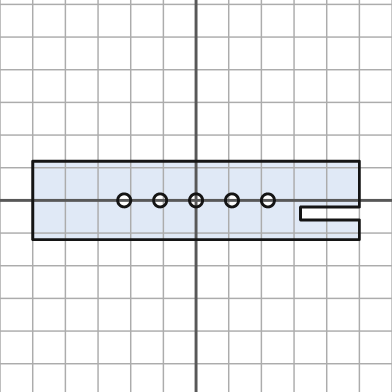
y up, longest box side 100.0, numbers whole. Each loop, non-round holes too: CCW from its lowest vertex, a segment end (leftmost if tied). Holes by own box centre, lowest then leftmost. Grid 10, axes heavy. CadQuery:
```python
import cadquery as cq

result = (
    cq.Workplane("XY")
    .moveTo(-50.0, -12.0)
    .lineTo(50.0, -12.0)
    .lineTo(50.0, -6.0)
    .lineTo(32.0, -6.0)
    .lineTo(32.0, -2.0)
    .lineTo(50.0, -2.0)
    .lineTo(50.0, 12.0)
    .lineTo(-50.0, 12.0)
    .close()
    .moveTo(-22.0, 0.0)
    .circle(2.0)
    .moveTo(-11.0, 0.0)
    .circle(2.0)
    .moveTo(0.0, 0.0)
    .circle(2.0)
    .moveTo(11.0, 0.0)
    .circle(2.0)
    .moveTo(22.0, 0.0)
    .circle(2.0)
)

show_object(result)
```